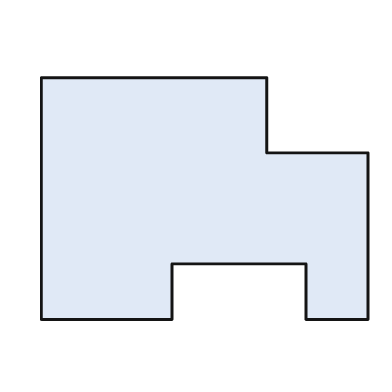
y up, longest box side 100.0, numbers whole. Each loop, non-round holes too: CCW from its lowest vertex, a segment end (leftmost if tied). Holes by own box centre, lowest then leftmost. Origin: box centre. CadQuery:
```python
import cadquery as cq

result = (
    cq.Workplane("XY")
    .moveTo(-50.0, -37.0)
    .lineTo(-10.0, -37.0)
    .lineTo(-10.0, -20.0)
    .lineTo(31.0, -20.0)
    .lineTo(31.0, -37.0)
    .lineTo(50.0, -37.0)
    .lineTo(50.0, 14.0)
    .lineTo(19.0, 14.0)
    .lineTo(19.0, 37.0)
    .lineTo(-50.0, 37.0)
    .close()
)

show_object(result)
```